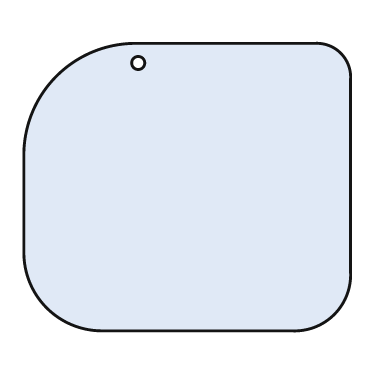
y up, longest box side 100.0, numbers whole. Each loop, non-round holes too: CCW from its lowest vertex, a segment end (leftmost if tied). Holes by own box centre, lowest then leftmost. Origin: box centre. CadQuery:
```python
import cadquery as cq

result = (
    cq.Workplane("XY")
    .moveTo(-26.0, -44.0)
    .lineTo(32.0, -44.0)
    .threePointArc((45.0, -39.0), (50.0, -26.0))
    .lineTo(50.0, 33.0)
    .threePointArc((47.0, 41.0), (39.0, 44.0))
    .lineTo(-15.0, 44.0)
    .threePointArc((-40.0, 34.0), (-50.0, 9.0))
    .lineTo(-50.0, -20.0)
    .threePointArc((-43.0, -37.0), (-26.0, -44.0))
    .close()
    .moveTo(-15.0, 38.0)
    .circle(2.0)
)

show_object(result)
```